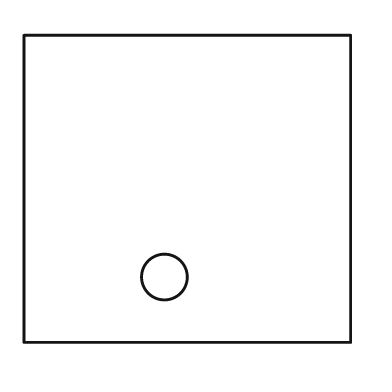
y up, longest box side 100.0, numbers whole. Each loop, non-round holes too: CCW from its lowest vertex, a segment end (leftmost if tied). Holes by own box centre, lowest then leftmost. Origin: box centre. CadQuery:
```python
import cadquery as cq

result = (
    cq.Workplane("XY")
    .moveTo(-50.0, -47.0)
    .lineTo(50.0, -47.0)
    .lineTo(50.0, 47.0)
    .lineTo(-50.0, 47.0)
    .close()
    .moveTo(-7.0, -27.0)
    .circle(7.0)
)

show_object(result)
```